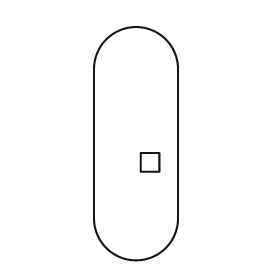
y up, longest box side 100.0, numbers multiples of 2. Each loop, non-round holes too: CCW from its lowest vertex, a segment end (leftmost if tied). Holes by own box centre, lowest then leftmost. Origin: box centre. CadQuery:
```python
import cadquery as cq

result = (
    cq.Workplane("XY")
    .moveTo(-18.0, -32.0)
    .threePointArc((0.0, -50.0), (18.0, -32.0))
    .lineTo(18.0, 32.0)
    .threePointArc((0.0, 50.0), (-18.0, 32.0))
    .close()
    .moveTo(2.0, -12.0)
    .lineTo(10.0, -12.0)
    .lineTo(10.0, -4.0)
    .lineTo(2.0, -4.0)
    .close()
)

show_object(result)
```